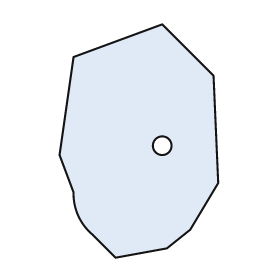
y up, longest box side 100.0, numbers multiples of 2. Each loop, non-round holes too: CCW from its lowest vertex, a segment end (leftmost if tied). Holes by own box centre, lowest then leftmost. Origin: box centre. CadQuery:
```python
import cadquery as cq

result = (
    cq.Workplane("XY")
    .moveTo(-10.0, -50.0)
    .lineTo(12.0, -46.0)
    .lineTo(22.0, -38.0)
    .lineTo(34.0, -18.0)
    .lineTo(32.0, 28.0)
    .lineTo(10.0, 50.0)
    .lineTo(-28.0, 36.0)
    .lineTo(-34.0, -6.0)
    .lineTo(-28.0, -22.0)
    .threePointArc((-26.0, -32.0), (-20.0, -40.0))
    .close()
    .moveTo(10.0, -2.0)
    .circle(4.0)
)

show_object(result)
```